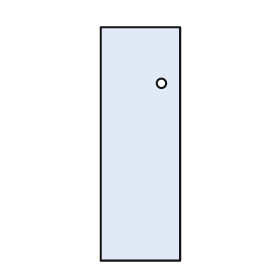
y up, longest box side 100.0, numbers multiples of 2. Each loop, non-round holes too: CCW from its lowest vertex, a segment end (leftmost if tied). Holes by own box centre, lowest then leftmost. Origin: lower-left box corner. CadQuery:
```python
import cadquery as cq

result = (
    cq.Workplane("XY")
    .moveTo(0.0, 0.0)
    .lineTo(34.0, 0.0)
    .lineTo(34.0, 100.0)
    .lineTo(0.0, 100.0)
    .close()
    .moveTo(26.0, 76.0)
    .circle(2.0)
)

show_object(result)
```